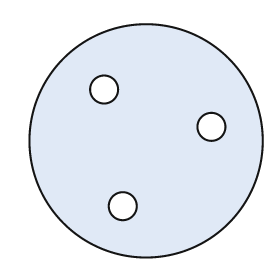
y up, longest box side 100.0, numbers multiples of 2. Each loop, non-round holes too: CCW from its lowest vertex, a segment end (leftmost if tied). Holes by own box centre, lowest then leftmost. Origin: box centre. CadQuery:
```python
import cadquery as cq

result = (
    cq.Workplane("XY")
    .moveTo(0.0, 0.0)
    .circle(50.0)
    .moveTo(-10.0, -28.0)
    .circle(6.0)
    .moveTo(28.0, 6.0)
    .circle(6.0)
    .moveTo(-18.0, 22.0)
    .circle(6.0)
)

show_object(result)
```